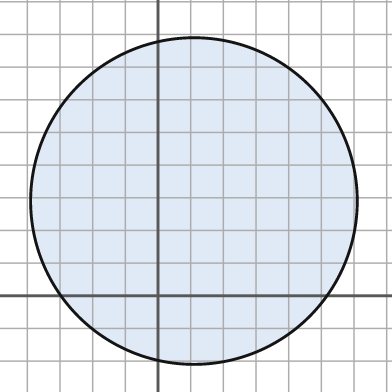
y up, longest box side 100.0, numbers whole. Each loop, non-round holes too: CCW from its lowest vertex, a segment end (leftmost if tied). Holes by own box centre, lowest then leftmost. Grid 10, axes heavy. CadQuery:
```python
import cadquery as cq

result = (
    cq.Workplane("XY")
    .moveTo(11.0, 29.0)
    .circle(50.0)
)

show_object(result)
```